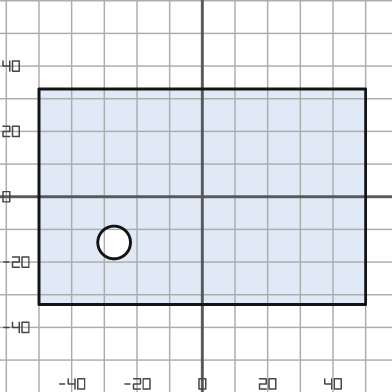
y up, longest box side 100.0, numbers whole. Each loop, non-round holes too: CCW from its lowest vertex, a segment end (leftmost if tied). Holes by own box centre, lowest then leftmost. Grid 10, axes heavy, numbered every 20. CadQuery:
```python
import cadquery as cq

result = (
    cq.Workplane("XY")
    .moveTo(-50.0, -33.0)
    .lineTo(50.0, -33.0)
    .lineTo(50.0, 33.0)
    .lineTo(-50.0, 33.0)
    .close()
    .moveTo(-27.0, -14.0)
    .circle(5.0)
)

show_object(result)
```